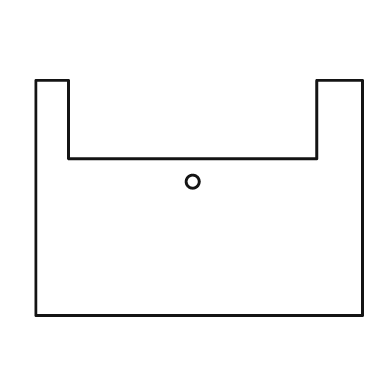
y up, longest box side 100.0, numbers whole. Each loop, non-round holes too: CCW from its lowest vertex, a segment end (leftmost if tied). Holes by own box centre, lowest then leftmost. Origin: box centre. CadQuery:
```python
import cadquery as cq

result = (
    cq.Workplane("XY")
    .moveTo(-50.0, -36.0)
    .lineTo(50.0, -36.0)
    .lineTo(50.0, 36.0)
    .lineTo(36.0, 36.0)
    .lineTo(36.0, 12.0)
    .lineTo(-40.0, 12.0)
    .lineTo(-40.0, 36.0)
    .lineTo(-50.0, 36.0)
    .close()
    .moveTo(-2.0, 5.0)
    .circle(2.0)
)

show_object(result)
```